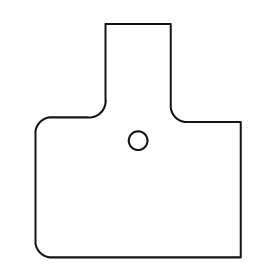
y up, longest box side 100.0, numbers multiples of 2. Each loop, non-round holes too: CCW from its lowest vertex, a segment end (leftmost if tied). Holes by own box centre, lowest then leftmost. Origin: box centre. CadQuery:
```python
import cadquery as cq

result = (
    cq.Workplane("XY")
    .moveTo(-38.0, -50.0)
    .lineTo(44.0, -50.0)
    .lineTo(44.0, 8.0)
    .lineTo(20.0, 8.0)
    .threePointArc((16.0, 10.0), (14.0, 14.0))
    .lineTo(14.0, 50.0)
    .lineTo(-14.0, 50.0)
    .lineTo(-14.0, 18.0)
    .threePointArc((-16.0, 12.0), (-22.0, 10.0))
    .lineTo(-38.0, 10.0)
    .threePointArc((-42.0, 8.0), (-44.0, 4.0))
    .lineTo(-44.0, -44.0)
    .threePointArc((-42.0, -48.0), (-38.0, -50.0))
    .close()
    .moveTo(0.0, 0.0)
    .circle(4.0)
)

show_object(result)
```